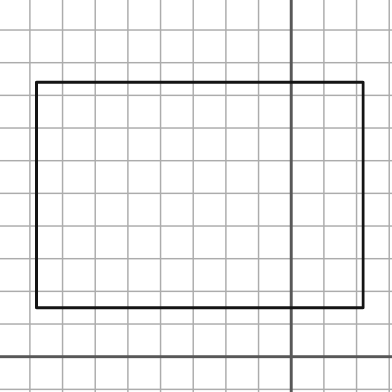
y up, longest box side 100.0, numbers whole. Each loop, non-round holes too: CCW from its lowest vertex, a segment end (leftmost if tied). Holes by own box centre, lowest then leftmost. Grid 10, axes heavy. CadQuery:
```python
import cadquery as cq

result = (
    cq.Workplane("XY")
    .moveTo(-78.0, 15.0)
    .lineTo(22.0, 15.0)
    .lineTo(22.0, 84.0)
    .lineTo(-78.0, 84.0)
    .close()
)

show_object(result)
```